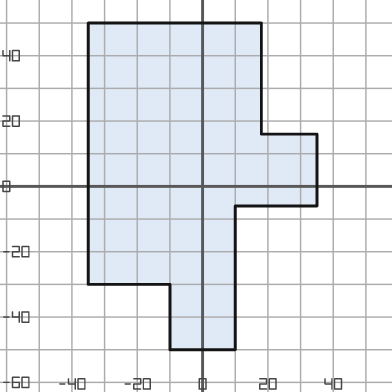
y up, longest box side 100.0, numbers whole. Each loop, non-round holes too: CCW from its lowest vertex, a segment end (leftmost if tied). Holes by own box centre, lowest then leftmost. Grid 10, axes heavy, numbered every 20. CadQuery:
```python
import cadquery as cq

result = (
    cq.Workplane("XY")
    .moveTo(-10.0, -50.0)
    .lineTo(10.0, -50.0)
    .lineTo(10.0, -6.0)
    .lineTo(35.0, -6.0)
    .lineTo(35.0, 16.0)
    .lineTo(18.0, 16.0)
    .lineTo(18.0, 50.0)
    .lineTo(-35.0, 50.0)
    .lineTo(-35.0, -30.0)
    .lineTo(-10.0, -30.0)
    .close()
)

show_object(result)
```